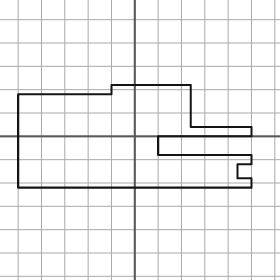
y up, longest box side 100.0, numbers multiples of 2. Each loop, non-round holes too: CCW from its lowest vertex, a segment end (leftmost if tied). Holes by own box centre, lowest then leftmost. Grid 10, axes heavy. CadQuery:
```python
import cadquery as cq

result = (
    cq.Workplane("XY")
    .moveTo(-50.0, -22.0)
    .lineTo(50.0, -22.0)
    .lineTo(50.0, -18.0)
    .lineTo(44.0, -18.0)
    .lineTo(44.0, -12.0)
    .lineTo(50.0, -12.0)
    .lineTo(50.0, -8.0)
    .lineTo(10.0, -8.0)
    .lineTo(10.0, 0.0)
    .lineTo(50.0, 0.0)
    .lineTo(50.0, 4.0)
    .lineTo(24.0, 4.0)
    .lineTo(24.0, 22.0)
    .lineTo(-10.0, 22.0)
    .lineTo(-10.0, 18.0)
    .lineTo(-50.0, 18.0)
    .close()
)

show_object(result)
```